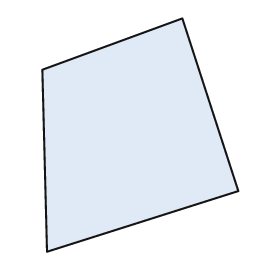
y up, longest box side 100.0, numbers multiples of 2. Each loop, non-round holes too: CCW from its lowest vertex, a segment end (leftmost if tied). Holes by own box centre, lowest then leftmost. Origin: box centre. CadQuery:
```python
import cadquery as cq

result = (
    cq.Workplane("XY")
    .moveTo(-40.0, -50.0)
    .lineTo(42.0, -24.0)
    .lineTo(18.0, 50.0)
    .lineTo(-42.0, 28.0)
    .close()
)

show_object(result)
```